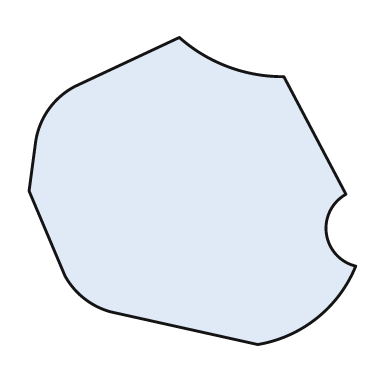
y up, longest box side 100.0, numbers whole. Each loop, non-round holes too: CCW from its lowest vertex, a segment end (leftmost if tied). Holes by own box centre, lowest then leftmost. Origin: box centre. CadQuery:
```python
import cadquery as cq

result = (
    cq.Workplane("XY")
    .moveTo(20.0, -47.0)
    .threePointArc((38.0, -39.0), (50.0, -23.0))
    .threePointArc((41.0, -13.0), (47.0, -1.0))
    .lineTo(28.0, 35.0)
    .threePointArc((11.0, 38.0), (-4.0, 47.0))
    .lineTo(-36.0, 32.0)
    .threePointArc((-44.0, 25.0), (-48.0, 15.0))
    .lineTo(-50.0, 0.0)
    .lineTo(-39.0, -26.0)
    .threePointArc((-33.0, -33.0), (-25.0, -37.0))
    .close()
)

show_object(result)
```